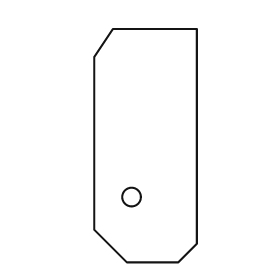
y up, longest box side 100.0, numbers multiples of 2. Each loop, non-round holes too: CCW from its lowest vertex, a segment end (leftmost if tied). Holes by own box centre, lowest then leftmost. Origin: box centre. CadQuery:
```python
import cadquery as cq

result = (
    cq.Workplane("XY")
    .moveTo(-8.0, -50.0)
    .lineTo(14.0, -50.0)
    .lineTo(22.0, -42.0)
    .lineTo(22.0, 50.0)
    .lineTo(-14.0, 50.0)
    .lineTo(-22.0, 38.0)
    .lineTo(-22.0, -36.0)
    .close()
    .moveTo(-6.0, -22.0)
    .circle(4.0)
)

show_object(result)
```